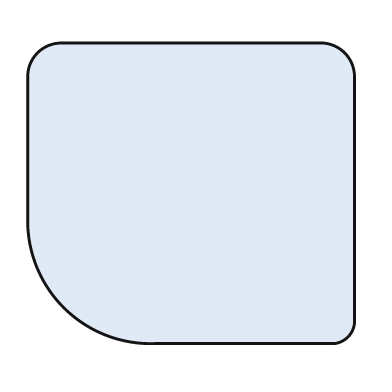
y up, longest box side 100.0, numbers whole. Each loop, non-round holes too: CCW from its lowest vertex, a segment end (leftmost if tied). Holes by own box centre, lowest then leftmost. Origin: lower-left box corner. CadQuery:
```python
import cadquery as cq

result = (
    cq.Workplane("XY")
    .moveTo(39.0, 0.0)
    .lineTo(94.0, 0.0)
    .threePointArc((98.0, 2.0), (100.0, 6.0))
    .lineTo(100.0, 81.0)
    .threePointArc((97.0, 89.0), (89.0, 92.0))
    .lineTo(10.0, 92.0)
    .threePointArc((3.0, 89.0), (0.0, 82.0))
    .lineTo(0.0, 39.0)
    .threePointArc((11.0, 11.0), (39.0, 0.0))
    .close()
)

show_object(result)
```